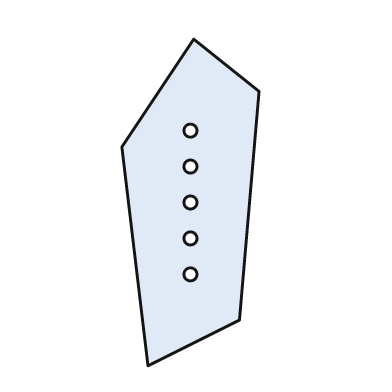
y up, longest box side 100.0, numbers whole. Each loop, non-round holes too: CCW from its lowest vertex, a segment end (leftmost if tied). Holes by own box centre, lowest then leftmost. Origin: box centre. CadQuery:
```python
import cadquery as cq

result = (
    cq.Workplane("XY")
    .moveTo(-13.0, -50.0)
    .lineTo(15.0, -36.0)
    .lineTo(21.0, 34.0)
    .lineTo(1.0, 50.0)
    .lineTo(-21.0, 17.0)
    .close()
    .moveTo(0.0, -22.0)
    .circle(2.0)
    .moveTo(0.0, -11.0)
    .circle(2.0)
    .moveTo(0.0, 0.0)
    .circle(2.0)
    .moveTo(0.0, 11.0)
    .circle(2.0)
    .moveTo(0.0, 22.0)
    .circle(2.0)
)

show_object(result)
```